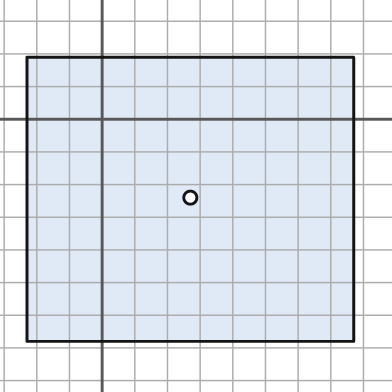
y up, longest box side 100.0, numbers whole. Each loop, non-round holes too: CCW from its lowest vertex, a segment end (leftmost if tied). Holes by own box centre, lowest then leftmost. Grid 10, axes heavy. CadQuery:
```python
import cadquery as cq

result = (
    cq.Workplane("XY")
    .moveTo(-23.0, -68.0)
    .lineTo(77.0, -68.0)
    .lineTo(77.0, 19.0)
    .lineTo(-23.0, 19.0)
    .close()
    .moveTo(27.0, -24.0)
    .circle(2.0)
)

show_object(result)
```